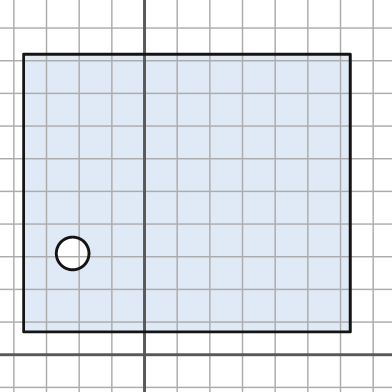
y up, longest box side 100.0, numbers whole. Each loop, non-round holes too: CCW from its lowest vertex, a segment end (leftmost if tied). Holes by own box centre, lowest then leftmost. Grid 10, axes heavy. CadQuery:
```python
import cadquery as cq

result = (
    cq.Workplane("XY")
    .moveTo(-37.0, 7.0)
    .lineTo(63.0, 7.0)
    .lineTo(63.0, 92.0)
    .lineTo(-37.0, 92.0)
    .close()
    .moveTo(-22.0, 31.0)
    .circle(5.0)
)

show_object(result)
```